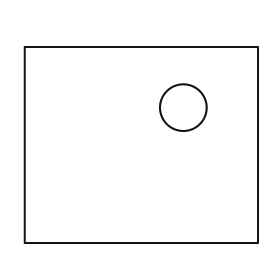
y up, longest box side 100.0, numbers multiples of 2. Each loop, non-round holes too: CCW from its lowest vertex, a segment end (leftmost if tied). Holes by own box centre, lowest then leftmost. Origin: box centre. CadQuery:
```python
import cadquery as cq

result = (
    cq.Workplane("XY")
    .moveTo(-50.0, -42.0)
    .lineTo(50.0, -42.0)
    .lineTo(50.0, 42.0)
    .lineTo(-50.0, 42.0)
    .close()
    .moveTo(18.0, 16.0)
    .circle(10.0)
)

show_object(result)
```